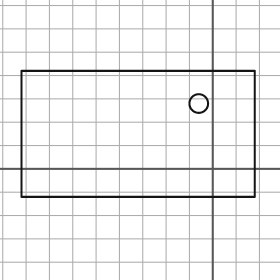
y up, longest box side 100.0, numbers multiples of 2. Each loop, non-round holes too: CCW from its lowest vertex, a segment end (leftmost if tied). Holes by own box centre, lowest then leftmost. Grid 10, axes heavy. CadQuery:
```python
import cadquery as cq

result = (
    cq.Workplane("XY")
    .moveTo(-82.0, -12.0)
    .lineTo(18.0, -12.0)
    .lineTo(18.0, 42.0)
    .lineTo(-82.0, 42.0)
    .close()
    .moveTo(-6.0, 28.0)
    .circle(4.0)
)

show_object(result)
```